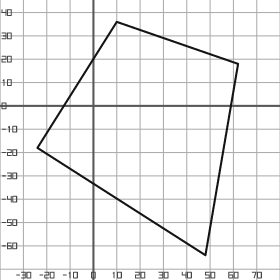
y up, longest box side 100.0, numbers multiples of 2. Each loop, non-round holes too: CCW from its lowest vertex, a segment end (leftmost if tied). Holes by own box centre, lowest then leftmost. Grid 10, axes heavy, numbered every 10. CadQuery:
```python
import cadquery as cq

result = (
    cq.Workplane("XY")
    .moveTo(48.0, -64.0)
    .lineTo(62.0, 18.0)
    .lineTo(10.0, 36.0)
    .lineTo(-24.0, -18.0)
    .close()
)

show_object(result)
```